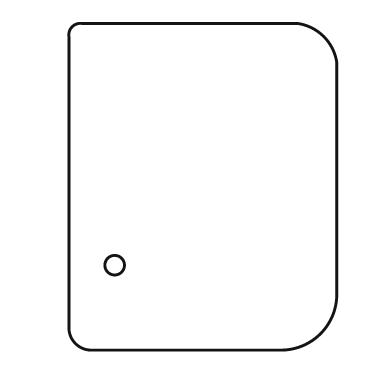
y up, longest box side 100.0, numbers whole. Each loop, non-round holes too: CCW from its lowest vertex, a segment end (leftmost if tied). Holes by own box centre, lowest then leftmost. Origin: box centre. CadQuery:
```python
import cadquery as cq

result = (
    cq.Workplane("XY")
    .moveTo(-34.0, -50.0)
    .lineTo(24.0, -50.0)
    .threePointArc((36.0, -45.0), (41.0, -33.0))
    .lineTo(41.0, 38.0)
    .threePointArc((37.0, 46.0), (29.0, 50.0))
    .lineTo(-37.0, 50.0)
    .threePointArc((-40.0, 49.0), (-41.0, 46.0))
    .lineTo(-41.0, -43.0)
    .threePointArc((-39.0, -48.0), (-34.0, -50.0))
    .close()
    .moveTo(-27.0, -24.0)
    .circle(3.0)
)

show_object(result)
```